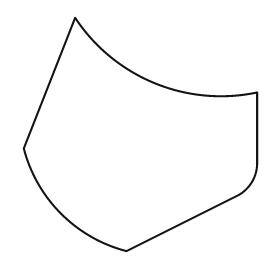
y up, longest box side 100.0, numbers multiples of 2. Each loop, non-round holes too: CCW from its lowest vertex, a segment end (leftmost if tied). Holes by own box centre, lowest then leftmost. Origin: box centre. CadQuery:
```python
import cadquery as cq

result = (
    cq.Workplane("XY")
    .moveTo(-6.0, -50.0)
    .lineTo(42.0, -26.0)
    .threePointArc((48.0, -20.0), (50.0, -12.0))
    .lineTo(50.0, 18.0)
    .threePointArc((6.0, 22.0), (-28.0, 50.0))
    .lineTo(-50.0, -6.0)
    .threePointArc((-34.0, -34.0), (-6.0, -50.0))
    .close()
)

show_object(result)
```